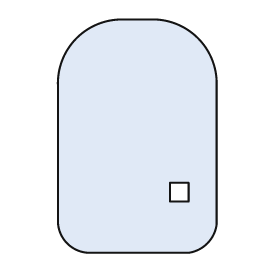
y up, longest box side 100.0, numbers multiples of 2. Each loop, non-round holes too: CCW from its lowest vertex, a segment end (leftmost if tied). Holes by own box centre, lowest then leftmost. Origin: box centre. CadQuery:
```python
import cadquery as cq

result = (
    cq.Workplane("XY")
    .moveTo(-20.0, -50.0)
    .lineTo(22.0, -50.0)
    .threePointArc((30.0, -46.0), (34.0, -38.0))
    .lineTo(34.0, 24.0)
    .threePointArc((26.0, 42.0), (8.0, 50.0))
    .lineTo(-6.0, 50.0)
    .threePointArc((-26.0, 42.0), (-34.0, 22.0))
    .lineTo(-34.0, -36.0)
    .threePointArc((-30.0, -46.0), (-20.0, -50.0))
    .close()
    .moveTo(14.0, -28.0)
    .lineTo(22.0, -28.0)
    .lineTo(22.0, -20.0)
    .lineTo(14.0, -20.0)
    .close()
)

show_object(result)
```